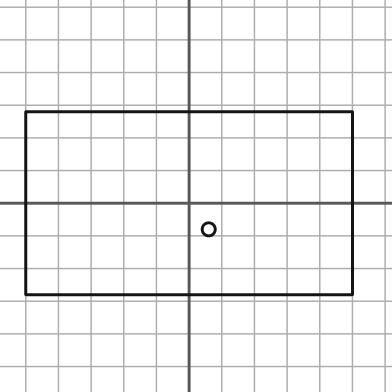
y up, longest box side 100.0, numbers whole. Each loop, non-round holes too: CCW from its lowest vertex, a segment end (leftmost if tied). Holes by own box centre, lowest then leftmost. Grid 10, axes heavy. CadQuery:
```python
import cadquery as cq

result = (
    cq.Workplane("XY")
    .moveTo(-50.0, -28.0)
    .lineTo(50.0, -28.0)
    .lineTo(50.0, 28.0)
    .lineTo(-50.0, 28.0)
    .close()
    .moveTo(6.0, -8.0)
    .circle(2.0)
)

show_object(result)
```